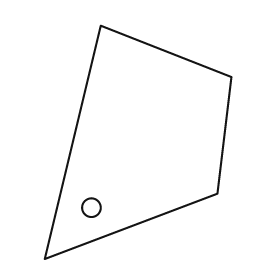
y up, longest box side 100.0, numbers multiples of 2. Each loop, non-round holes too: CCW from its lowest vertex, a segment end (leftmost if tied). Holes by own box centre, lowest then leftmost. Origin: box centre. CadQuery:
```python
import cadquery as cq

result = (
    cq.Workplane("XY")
    .moveTo(-40.0, -50.0)
    .lineTo(34.0, -22.0)
    .lineTo(40.0, 28.0)
    .lineTo(-16.0, 50.0)
    .close()
    .moveTo(-20.0, -28.0)
    .circle(4.0)
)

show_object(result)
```